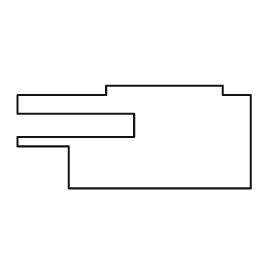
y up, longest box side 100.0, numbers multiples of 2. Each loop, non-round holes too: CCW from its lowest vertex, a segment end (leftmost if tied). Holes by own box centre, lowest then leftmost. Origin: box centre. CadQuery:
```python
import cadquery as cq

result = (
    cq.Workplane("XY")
    .moveTo(-28.0, -22.0)
    .lineTo(50.0, -22.0)
    .lineTo(50.0, 18.0)
    .lineTo(38.0, 18.0)
    .lineTo(38.0, 22.0)
    .lineTo(-12.0, 22.0)
    .lineTo(-12.0, 18.0)
    .lineTo(-50.0, 18.0)
    .lineTo(-50.0, 10.0)
    .lineTo(0.0, 10.0)
    .lineTo(0.0, 0.0)
    .lineTo(-50.0, 0.0)
    .lineTo(-50.0, -4.0)
    .lineTo(-28.0, -4.0)
    .close()
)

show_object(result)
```